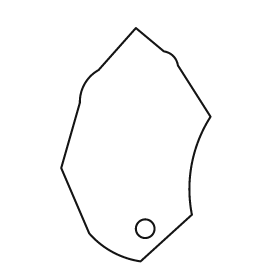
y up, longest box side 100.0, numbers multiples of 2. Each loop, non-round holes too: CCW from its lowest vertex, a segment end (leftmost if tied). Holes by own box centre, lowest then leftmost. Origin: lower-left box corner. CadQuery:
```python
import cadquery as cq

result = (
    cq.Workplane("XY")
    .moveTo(34.0, 0.0)
    .lineTo(56.0, 20.0)
    .threePointArc((56.0, 42.0), (64.0, 62.0))
    .lineTo(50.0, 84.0)
    .threePointArc((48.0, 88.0), (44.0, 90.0))
    .lineTo(32.0, 100.0)
    .lineTo(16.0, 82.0)
    .threePointArc((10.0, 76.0), (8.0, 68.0))
    .lineTo(0.0, 40.0)
    .lineTo(12.0, 12.0)
    .threePointArc((22.0, 4.0), (34.0, 0.0))
    .close()
    .moveTo(36.0, 14.0)
    .circle(4.0)
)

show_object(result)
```